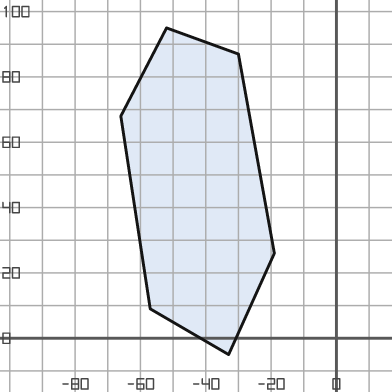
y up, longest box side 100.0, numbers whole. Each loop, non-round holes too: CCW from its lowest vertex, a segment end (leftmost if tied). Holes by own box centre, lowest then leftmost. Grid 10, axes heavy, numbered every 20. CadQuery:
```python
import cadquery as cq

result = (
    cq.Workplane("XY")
    .moveTo(-33.0, -5.0)
    .lineTo(-19.0, 26.0)
    .lineTo(-30.0, 87.0)
    .lineTo(-52.0, 95.0)
    .lineTo(-66.0, 68.0)
    .lineTo(-57.0, 9.0)
    .close()
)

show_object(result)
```